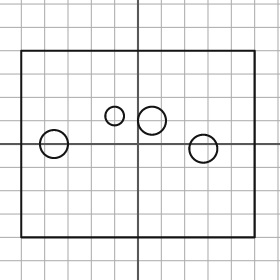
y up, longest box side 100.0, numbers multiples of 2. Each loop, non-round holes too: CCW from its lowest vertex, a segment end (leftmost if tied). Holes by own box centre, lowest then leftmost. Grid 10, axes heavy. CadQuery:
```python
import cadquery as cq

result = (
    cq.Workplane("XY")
    .moveTo(-50.0, -40.0)
    .lineTo(50.0, -40.0)
    .lineTo(50.0, 40.0)
    .lineTo(-50.0, 40.0)
    .close()
    .moveTo(28.0, -2.0)
    .circle(6.0)
    .moveTo(-36.0, 0.0)
    .circle(6.0)
    .moveTo(6.0, 10.0)
    .circle(6.0)
    .moveTo(-10.0, 12.0)
    .circle(4.0)
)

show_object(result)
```